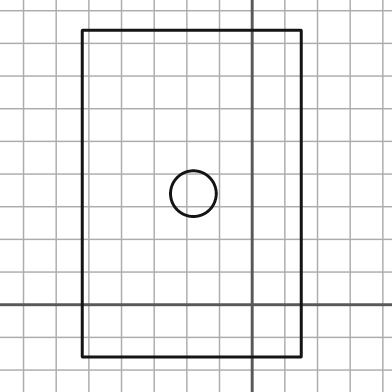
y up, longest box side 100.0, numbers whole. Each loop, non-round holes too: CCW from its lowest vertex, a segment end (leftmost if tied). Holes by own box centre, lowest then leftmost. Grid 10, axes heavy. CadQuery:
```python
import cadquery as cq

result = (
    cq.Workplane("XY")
    .moveTo(-52.0, -16.0)
    .lineTo(15.0, -16.0)
    .lineTo(15.0, 84.0)
    .lineTo(-52.0, 84.0)
    .close()
    .moveTo(-18.0, 34.0)
    .circle(7.0)
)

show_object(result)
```